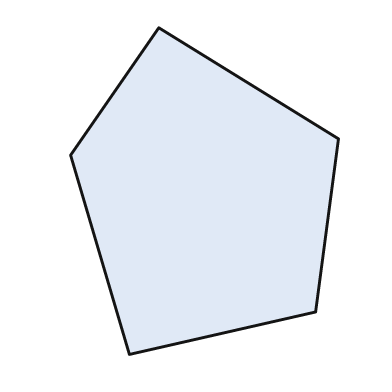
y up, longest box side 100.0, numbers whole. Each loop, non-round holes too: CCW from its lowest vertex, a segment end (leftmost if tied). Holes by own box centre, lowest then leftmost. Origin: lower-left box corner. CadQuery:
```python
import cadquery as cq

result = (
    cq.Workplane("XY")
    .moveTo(18.0, 0.0)
    .lineTo(75.0, 13.0)
    .lineTo(82.0, 66.0)
    .lineTo(27.0, 100.0)
    .lineTo(0.0, 61.0)
    .close()
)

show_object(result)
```